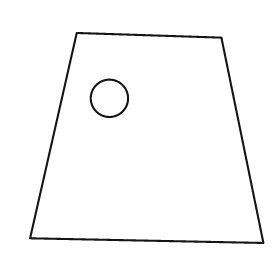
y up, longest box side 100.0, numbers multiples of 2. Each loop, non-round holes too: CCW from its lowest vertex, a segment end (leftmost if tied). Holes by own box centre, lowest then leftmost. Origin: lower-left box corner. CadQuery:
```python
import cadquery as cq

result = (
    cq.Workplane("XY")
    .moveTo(100.0, 0.0)
    .lineTo(82.0, 88.0)
    .lineTo(20.0, 90.0)
    .lineTo(0.0, 2.0)
    .close()
    .moveTo(34.0, 62.0)
    .circle(8.0)
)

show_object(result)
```